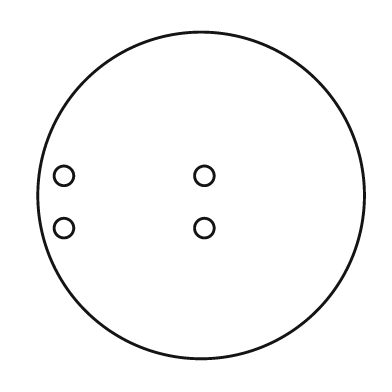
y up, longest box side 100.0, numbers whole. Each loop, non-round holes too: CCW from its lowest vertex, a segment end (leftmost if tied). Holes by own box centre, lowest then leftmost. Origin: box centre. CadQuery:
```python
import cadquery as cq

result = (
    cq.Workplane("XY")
    .moveTo(0.0, 0.0)
    .circle(50.0)
    .moveTo(-42.0, -10.0)
    .circle(3.0)
    .moveTo(1.0, -10.0)
    .circle(3.0)
    .moveTo(-42.0, 6.0)
    .circle(3.0)
    .moveTo(1.0, 6.0)
    .circle(3.0)
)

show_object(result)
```